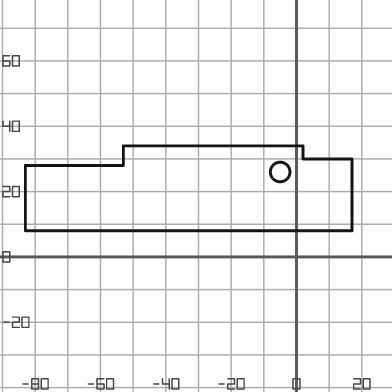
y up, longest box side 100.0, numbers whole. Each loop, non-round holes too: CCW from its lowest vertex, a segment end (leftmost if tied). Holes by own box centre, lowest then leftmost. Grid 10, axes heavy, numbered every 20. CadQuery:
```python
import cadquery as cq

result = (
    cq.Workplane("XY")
    .moveTo(-83.0, 8.0)
    .lineTo(17.0, 8.0)
    .lineTo(17.0, 30.0)
    .lineTo(2.0, 30.0)
    .lineTo(2.0, 34.0)
    .lineTo(-53.0, 34.0)
    .lineTo(-53.0, 28.0)
    .lineTo(-83.0, 28.0)
    .close()
    .moveTo(-5.0, 26.0)
    .circle(3.0)
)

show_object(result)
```